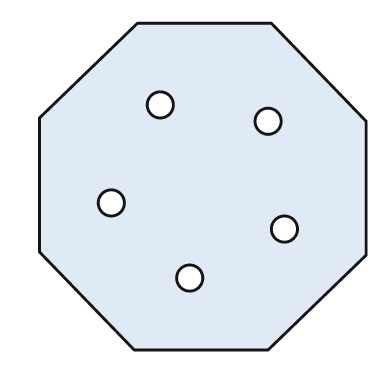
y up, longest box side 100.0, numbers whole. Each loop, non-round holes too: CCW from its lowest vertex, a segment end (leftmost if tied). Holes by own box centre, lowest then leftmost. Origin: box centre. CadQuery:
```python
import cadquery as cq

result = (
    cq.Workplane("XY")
    .moveTo(-21.0, -50.0)
    .lineTo(20.0, -50.0)
    .lineTo(50.0, -21.0)
    .lineTo(50.0, 20.0)
    .lineTo(21.0, 50.0)
    .lineTo(-20.0, 50.0)
    .lineTo(-50.0, 21.0)
    .lineTo(-50.0, -20.0)
    .close()
    .moveTo(-4.0, -28.0)
    .circle(4.0)
    .moveTo(25.0, -13.0)
    .circle(4.0)
    .moveTo(-28.0, -5.0)
    .circle(4.0)
    .moveTo(20.0, 20.0)
    .circle(4.0)
    .moveTo(-13.0, 25.0)
    .circle(4.0)
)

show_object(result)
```